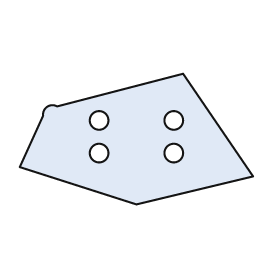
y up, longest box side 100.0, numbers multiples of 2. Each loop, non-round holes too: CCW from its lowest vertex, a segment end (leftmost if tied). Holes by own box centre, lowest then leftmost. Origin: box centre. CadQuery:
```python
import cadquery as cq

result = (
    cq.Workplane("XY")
    .moveTo(0.0, -28.0)
    .lineTo(50.0, -16.0)
    .lineTo(20.0, 28.0)
    .lineTo(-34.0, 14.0)
    .threePointArc((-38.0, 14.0), (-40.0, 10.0))
    .lineTo(-50.0, -12.0)
    .close()
    .moveTo(-16.0, -6.0)
    .circle(4.0)
    .moveTo(16.0, -6.0)
    .circle(4.0)
    .moveTo(-16.0, 8.0)
    .circle(4.0)
    .moveTo(16.0, 8.0)
    .circle(4.0)
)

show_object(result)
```